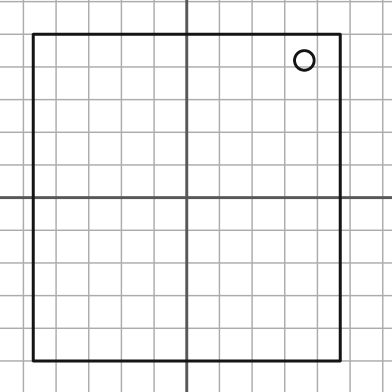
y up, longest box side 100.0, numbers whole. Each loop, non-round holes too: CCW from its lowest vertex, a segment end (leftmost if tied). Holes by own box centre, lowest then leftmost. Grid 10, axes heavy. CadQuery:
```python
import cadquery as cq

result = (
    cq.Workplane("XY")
    .moveTo(-47.0, -50.0)
    .lineTo(47.0, -50.0)
    .lineTo(47.0, 50.0)
    .lineTo(-47.0, 50.0)
    .close()
    .moveTo(36.0, 42.0)
    .circle(3.0)
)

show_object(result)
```